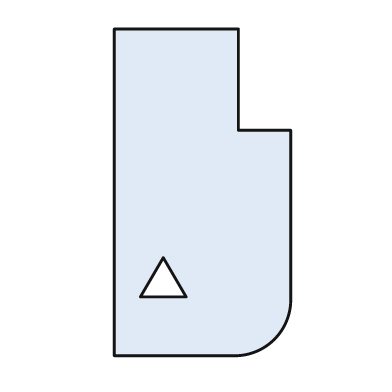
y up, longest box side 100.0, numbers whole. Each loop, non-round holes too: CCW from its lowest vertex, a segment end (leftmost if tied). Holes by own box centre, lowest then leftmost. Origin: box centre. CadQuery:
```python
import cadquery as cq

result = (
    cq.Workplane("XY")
    .moveTo(-27.0, -50.0)
    .lineTo(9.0, -50.0)
    .threePointArc((22.0, -45.0), (27.0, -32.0))
    .lineTo(27.0, 19.0)
    .lineTo(11.0, 19.0)
    .lineTo(11.0, 50.0)
    .lineTo(-27.0, 50.0)
    .close()
    .moveTo(-19.0, -32.0)
    .lineTo(-5.0, -32.0)
    .lineTo(-12.0, -20.0)
    .close()
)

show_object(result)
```